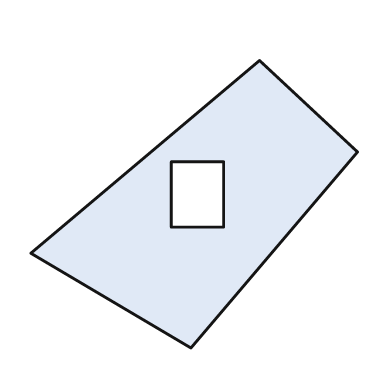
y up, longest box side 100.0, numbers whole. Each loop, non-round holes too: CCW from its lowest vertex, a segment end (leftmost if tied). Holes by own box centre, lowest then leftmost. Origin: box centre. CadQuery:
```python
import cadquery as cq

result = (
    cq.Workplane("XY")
    .moveTo(-1.0, -44.0)
    .lineTo(50.0, 16.0)
    .lineTo(20.0, 44.0)
    .lineTo(-50.0, -15.0)
    .close()
    .moveTo(-7.0, -7.0)
    .lineTo(9.0, -7.0)
    .lineTo(9.0, 13.0)
    .lineTo(-7.0, 13.0)
    .close()
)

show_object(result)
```